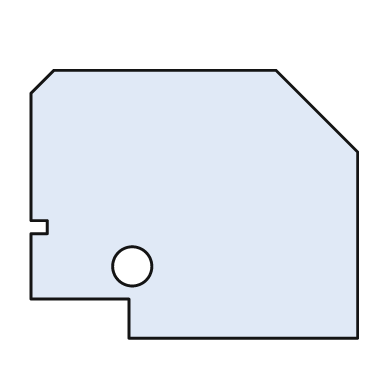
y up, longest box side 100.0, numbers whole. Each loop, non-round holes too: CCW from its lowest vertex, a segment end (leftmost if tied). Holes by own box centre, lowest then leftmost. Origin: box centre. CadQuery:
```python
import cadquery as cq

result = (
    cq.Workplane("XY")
    .moveTo(-20.0, -41.0)
    .lineTo(50.0, -41.0)
    .lineTo(50.0, 16.0)
    .lineTo(25.0, 41.0)
    .lineTo(-43.0, 41.0)
    .lineTo(-50.0, 34.0)
    .lineTo(-50.0, -5.0)
    .lineTo(-45.0, -5.0)
    .lineTo(-45.0, -9.0)
    .lineTo(-50.0, -9.0)
    .lineTo(-50.0, -29.0)
    .lineTo(-20.0, -29.0)
    .close()
    .moveTo(-19.0, -19.0)
    .circle(6.0)
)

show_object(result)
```